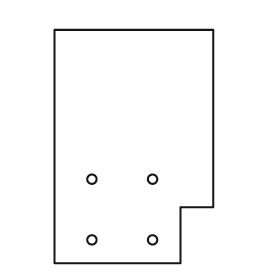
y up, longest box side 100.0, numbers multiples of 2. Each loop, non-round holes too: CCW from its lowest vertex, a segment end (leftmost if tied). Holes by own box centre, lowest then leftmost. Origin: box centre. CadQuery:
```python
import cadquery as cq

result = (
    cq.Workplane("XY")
    .moveTo(-34.0, -50.0)
    .lineTo(20.0, -50.0)
    .lineTo(20.0, -26.0)
    .lineTo(34.0, -26.0)
    .lineTo(34.0, 50.0)
    .lineTo(-34.0, 50.0)
    .close()
    .moveTo(-18.0, -40.0)
    .circle(2.0)
    .moveTo(8.0, -40.0)
    .circle(2.0)
    .moveTo(-18.0, -14.0)
    .circle(2.0)
    .moveTo(8.0, -14.0)
    .circle(2.0)
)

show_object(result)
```